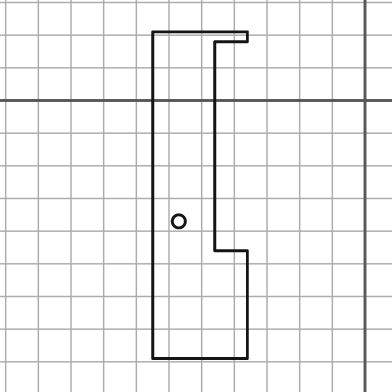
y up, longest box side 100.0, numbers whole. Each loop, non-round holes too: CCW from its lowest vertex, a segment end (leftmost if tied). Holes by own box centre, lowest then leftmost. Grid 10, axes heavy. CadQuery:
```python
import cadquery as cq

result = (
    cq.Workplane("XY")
    .moveTo(-65.0, -79.0)
    .lineTo(-36.0, -79.0)
    .lineTo(-36.0, -46.0)
    .lineTo(-46.0, -46.0)
    .lineTo(-46.0, 18.0)
    .lineTo(-36.0, 18.0)
    .lineTo(-36.0, 21.0)
    .lineTo(-65.0, 21.0)
    .close()
    .moveTo(-57.0, -37.0)
    .circle(2.0)
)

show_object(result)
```